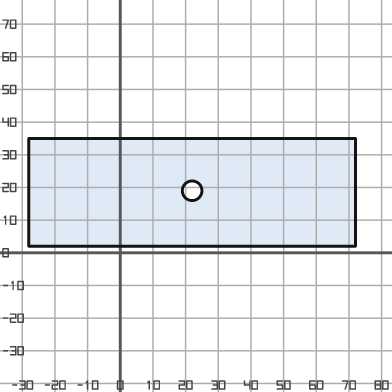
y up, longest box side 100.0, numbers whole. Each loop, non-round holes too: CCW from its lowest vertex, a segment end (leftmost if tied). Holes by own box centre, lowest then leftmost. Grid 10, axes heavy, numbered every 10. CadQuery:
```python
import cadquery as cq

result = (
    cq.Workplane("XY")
    .moveTo(-28.0, 2.0)
    .lineTo(72.0, 2.0)
    .lineTo(72.0, 35.0)
    .lineTo(-28.0, 35.0)
    .close()
    .moveTo(22.0, 19.0)
    .circle(3.0)
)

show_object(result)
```